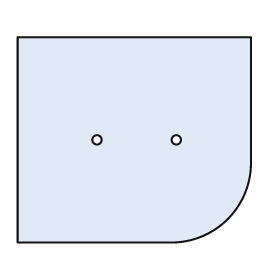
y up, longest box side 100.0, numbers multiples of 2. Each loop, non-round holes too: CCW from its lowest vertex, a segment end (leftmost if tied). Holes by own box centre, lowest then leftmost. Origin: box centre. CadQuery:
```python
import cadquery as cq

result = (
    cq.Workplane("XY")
    .moveTo(-50.0, -44.0)
    .lineTo(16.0, -44.0)
    .threePointArc((40.0, -34.0), (50.0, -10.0))
    .lineTo(50.0, 44.0)
    .lineTo(-50.0, 44.0)
    .close()
    .moveTo(-16.0, 0.0)
    .circle(2.0)
    .moveTo(18.0, 0.0)
    .circle(2.0)
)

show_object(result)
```